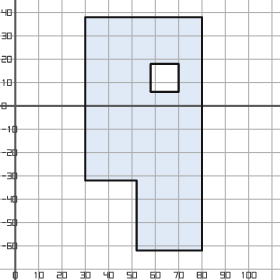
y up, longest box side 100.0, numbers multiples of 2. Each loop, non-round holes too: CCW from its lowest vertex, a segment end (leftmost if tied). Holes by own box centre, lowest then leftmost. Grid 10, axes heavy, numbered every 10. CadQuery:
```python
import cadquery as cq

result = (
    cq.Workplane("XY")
    .moveTo(52.0, -62.0)
    .lineTo(80.0, -62.0)
    .lineTo(80.0, 38.0)
    .lineTo(30.0, 38.0)
    .lineTo(30.0, -32.0)
    .lineTo(52.0, -32.0)
    .close()
    .moveTo(58.0, 6.0)
    .lineTo(70.0, 6.0)
    .lineTo(70.0, 18.0)
    .lineTo(58.0, 18.0)
    .close()
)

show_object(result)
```